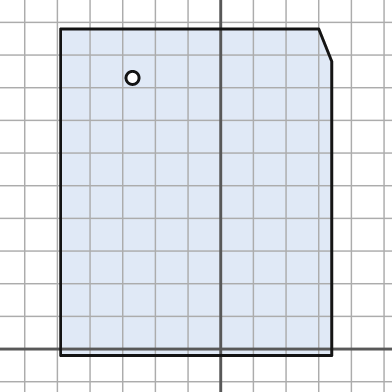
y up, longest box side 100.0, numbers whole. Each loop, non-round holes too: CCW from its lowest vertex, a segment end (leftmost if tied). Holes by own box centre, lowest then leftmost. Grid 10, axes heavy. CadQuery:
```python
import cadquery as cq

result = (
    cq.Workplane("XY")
    .moveTo(-49.0, -2.0)
    .lineTo(34.0, -2.0)
    .lineTo(34.0, 88.0)
    .lineTo(30.0, 98.0)
    .lineTo(-49.0, 98.0)
    .close()
    .moveTo(-27.0, 83.0)
    .circle(2.0)
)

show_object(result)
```